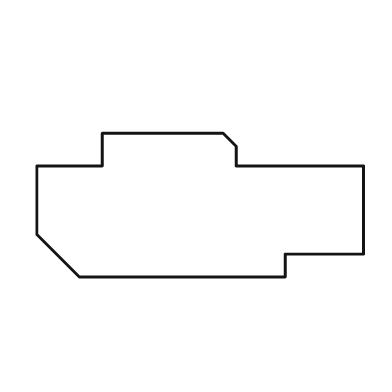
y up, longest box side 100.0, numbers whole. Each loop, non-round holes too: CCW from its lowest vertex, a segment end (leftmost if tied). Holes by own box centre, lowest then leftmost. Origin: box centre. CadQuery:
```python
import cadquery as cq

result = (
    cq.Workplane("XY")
    .moveTo(-37.0, -22.0)
    .lineTo(26.0, -22.0)
    .lineTo(26.0, -15.0)
    .lineTo(50.0, -15.0)
    .lineTo(50.0, 12.0)
    .lineTo(11.0, 12.0)
    .lineTo(11.0, 18.0)
    .lineTo(7.0, 22.0)
    .lineTo(-30.0, 22.0)
    .lineTo(-30.0, 12.0)
    .lineTo(-50.0, 12.0)
    .lineTo(-50.0, -9.0)
    .close()
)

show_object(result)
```